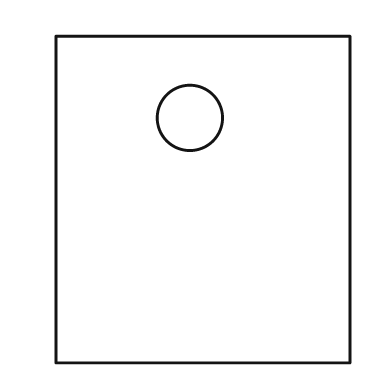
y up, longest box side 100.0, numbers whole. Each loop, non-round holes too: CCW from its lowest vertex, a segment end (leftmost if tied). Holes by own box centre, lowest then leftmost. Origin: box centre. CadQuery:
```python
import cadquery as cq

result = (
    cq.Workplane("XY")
    .moveTo(-45.0, -50.0)
    .lineTo(45.0, -50.0)
    .lineTo(45.0, 50.0)
    .lineTo(-45.0, 50.0)
    .close()
    .moveTo(-4.0, 25.0)
    .circle(10.0)
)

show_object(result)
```